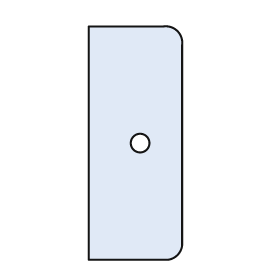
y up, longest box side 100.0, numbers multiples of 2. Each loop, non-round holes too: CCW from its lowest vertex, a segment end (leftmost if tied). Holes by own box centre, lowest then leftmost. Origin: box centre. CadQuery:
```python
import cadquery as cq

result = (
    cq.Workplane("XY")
    .moveTo(-20.0, -50.0)
    .lineTo(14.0, -50.0)
    .threePointArc((18.0, -48.0), (20.0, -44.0))
    .lineTo(20.0, 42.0)
    .threePointArc((18.0, 48.0), (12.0, 50.0))
    .lineTo(-20.0, 50.0)
    .close()
    .moveTo(2.0, 0.0)
    .circle(4.0)
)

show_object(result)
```